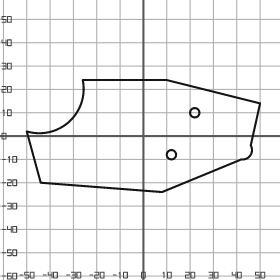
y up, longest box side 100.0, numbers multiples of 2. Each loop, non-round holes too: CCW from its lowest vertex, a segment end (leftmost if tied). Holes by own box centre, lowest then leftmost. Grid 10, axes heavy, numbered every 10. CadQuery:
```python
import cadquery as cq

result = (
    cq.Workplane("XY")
    .moveTo(8.0, -24.0)
    .lineTo(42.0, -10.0)
    .threePointArc((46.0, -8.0), (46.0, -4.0))
    .lineTo(50.0, 14.0)
    .lineTo(10.0, 24.0)
    .lineTo(-26.0, 24.0)
    .threePointArc((-32.0, 6.0), (-50.0, 2.0))
    .lineTo(-44.0, -20.0)
    .close()
    .moveTo(12.0, -8.0)
    .circle(2.0)
    .moveTo(22.0, 10.0)
    .circle(2.0)
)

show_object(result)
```